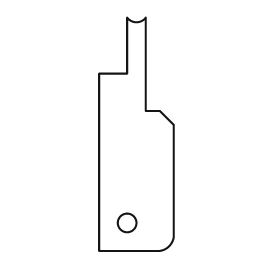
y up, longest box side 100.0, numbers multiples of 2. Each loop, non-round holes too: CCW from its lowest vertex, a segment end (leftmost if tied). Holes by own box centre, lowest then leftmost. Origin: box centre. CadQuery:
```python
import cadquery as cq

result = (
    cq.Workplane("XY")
    .moveTo(-16.0, -50.0)
    .lineTo(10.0, -50.0)
    .threePointArc((14.0, -48.0), (16.0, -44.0))
    .lineTo(16.0, 4.0)
    .lineTo(10.0, 10.0)
    .lineTo(4.0, 10.0)
    .lineTo(4.0, 50.0)
    .threePointArc((0.0, 48.0), (-4.0, 50.0))
    .lineTo(-4.0, 26.0)
    .lineTo(-16.0, 26.0)
    .close()
    .moveTo(-4.0, -38.0)
    .circle(4.0)
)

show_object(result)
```